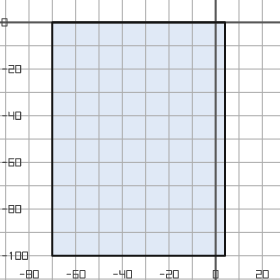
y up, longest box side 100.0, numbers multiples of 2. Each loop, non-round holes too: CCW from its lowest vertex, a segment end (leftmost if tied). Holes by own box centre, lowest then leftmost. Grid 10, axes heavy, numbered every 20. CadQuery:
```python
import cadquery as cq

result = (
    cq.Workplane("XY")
    .moveTo(-70.0, -100.0)
    .lineTo(4.0, -100.0)
    .lineTo(4.0, 0.0)
    .lineTo(-70.0, 0.0)
    .close()
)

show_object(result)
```